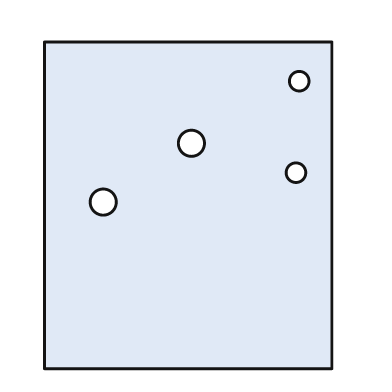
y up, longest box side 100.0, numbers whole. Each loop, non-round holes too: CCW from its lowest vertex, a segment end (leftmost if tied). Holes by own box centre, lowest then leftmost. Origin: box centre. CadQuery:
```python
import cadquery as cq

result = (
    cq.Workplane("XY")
    .moveTo(-44.0, -50.0)
    .lineTo(44.0, -50.0)
    .lineTo(44.0, 50.0)
    .lineTo(-44.0, 50.0)
    .close()
    .moveTo(-26.0, 1.0)
    .circle(4.0)
    .moveTo(33.0, 10.0)
    .circle(3.0)
    .moveTo(1.0, 19.0)
    .circle(4.0)
    .moveTo(34.0, 38.0)
    .circle(3.0)
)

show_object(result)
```